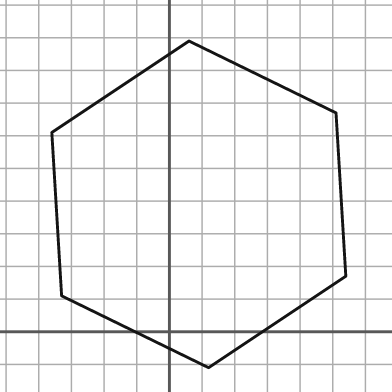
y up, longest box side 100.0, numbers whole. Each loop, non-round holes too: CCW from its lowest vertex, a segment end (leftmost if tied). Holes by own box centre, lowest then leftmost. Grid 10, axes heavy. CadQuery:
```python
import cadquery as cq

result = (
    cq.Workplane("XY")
    .moveTo(12.0, -11.0)
    .lineTo(54.0, 17.0)
    .lineTo(51.0, 67.0)
    .lineTo(6.0, 89.0)
    .lineTo(-36.0, 61.0)
    .lineTo(-33.0, 11.0)
    .close()
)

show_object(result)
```